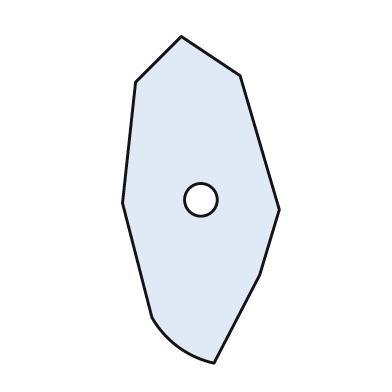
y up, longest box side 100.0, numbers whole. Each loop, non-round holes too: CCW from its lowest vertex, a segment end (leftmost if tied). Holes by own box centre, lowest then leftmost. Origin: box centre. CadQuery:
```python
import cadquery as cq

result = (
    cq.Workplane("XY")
    .moveTo(4.0, -50.0)
    .lineTo(18.0, -23.0)
    .lineTo(24.0, -3.0)
    .lineTo(12.0, 38.0)
    .lineTo(-6.0, 50.0)
    .lineTo(-20.0, 36.0)
    .lineTo(-24.0, -1.0)
    .lineTo(-15.0, -36.0)
    .threePointArc((-7.0, -45.0), (4.0, -50.0))
    .close()
    .moveTo(0.0, 0.0)
    .circle(5.0)
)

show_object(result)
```